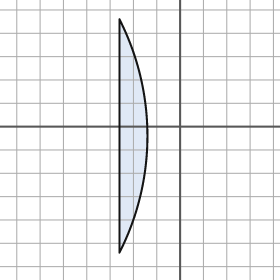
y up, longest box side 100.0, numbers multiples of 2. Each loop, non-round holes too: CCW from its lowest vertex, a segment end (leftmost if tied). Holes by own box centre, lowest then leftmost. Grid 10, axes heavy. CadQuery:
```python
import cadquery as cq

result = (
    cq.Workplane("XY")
    .moveTo(-26.0, -54.0)
    .threePointArc((-14.0, -4.0), (-26.0, 46.0))
    .close()
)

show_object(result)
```